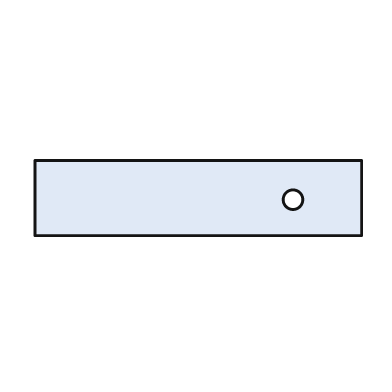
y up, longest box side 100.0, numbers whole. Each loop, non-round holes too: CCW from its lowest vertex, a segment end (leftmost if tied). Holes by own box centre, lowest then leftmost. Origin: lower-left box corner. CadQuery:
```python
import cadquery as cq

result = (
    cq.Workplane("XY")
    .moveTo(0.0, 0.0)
    .lineTo(100.0, 0.0)
    .lineTo(100.0, 23.0)
    .lineTo(0.0, 23.0)
    .close()
    .moveTo(79.0, 11.0)
    .circle(3.0)
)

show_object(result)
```